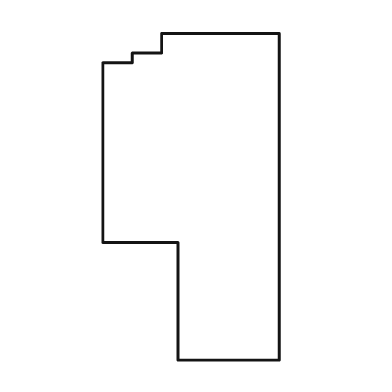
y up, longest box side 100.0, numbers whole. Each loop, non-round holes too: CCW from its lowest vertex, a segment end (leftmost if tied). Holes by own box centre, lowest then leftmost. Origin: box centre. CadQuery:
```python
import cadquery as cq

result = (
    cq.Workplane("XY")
    .moveTo(-4.0, -50.0)
    .lineTo(27.0, -50.0)
    .lineTo(27.0, 50.0)
    .lineTo(-9.0, 50.0)
    .lineTo(-9.0, 44.0)
    .lineTo(-18.0, 44.0)
    .lineTo(-18.0, 41.0)
    .lineTo(-27.0, 41.0)
    .lineTo(-27.0, -14.0)
    .lineTo(-4.0, -14.0)
    .close()
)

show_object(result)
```